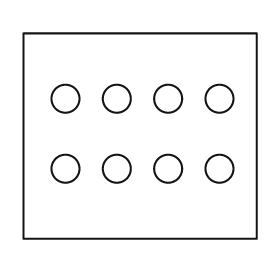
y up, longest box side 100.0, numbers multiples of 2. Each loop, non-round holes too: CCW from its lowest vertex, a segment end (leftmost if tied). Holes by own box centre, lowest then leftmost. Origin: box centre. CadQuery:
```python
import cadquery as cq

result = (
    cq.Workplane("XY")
    .moveTo(-50.0, -44.0)
    .lineTo(50.0, -44.0)
    .lineTo(50.0, 44.0)
    .lineTo(-50.0, 44.0)
    .close()
    .moveTo(-32.0, -14.0)
    .circle(6.0)
    .moveTo(-10.0, -14.0)
    .circle(6.0)
    .moveTo(12.0, -14.0)
    .circle(6.0)
    .moveTo(34.0, -14.0)
    .circle(6.0)
    .moveTo(-32.0, 16.0)
    .circle(6.0)
    .moveTo(-10.0, 16.0)
    .circle(6.0)
    .moveTo(12.0, 16.0)
    .circle(6.0)
    .moveTo(34.0, 16.0)
    .circle(6.0)
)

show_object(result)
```